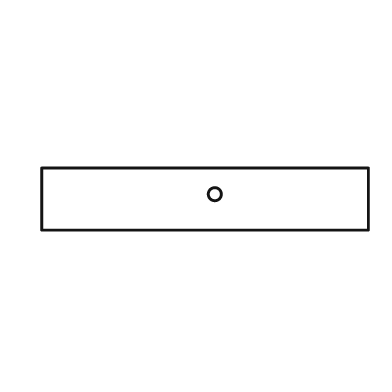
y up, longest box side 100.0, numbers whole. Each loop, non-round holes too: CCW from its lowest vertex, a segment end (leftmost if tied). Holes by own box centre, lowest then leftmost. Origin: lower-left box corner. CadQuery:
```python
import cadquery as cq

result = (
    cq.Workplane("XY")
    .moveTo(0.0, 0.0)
    .lineTo(100.0, 0.0)
    .lineTo(100.0, 19.0)
    .lineTo(0.0, 19.0)
    .close()
    .moveTo(53.0, 11.0)
    .circle(2.0)
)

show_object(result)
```